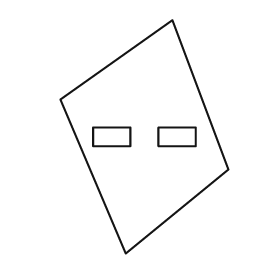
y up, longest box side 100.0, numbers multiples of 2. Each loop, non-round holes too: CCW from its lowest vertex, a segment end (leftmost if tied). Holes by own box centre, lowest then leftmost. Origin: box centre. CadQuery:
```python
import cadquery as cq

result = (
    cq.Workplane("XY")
    .moveTo(-8.0, -50.0)
    .lineTo(36.0, -14.0)
    .lineTo(12.0, 50.0)
    .lineTo(-36.0, 16.0)
    .close()
    .moveTo(-22.0, -4.0)
    .lineTo(-6.0, -4.0)
    .lineTo(-6.0, 4.0)
    .lineTo(-22.0, 4.0)
    .close()
    .moveTo(6.0, -4.0)
    .lineTo(22.0, -4.0)
    .lineTo(22.0, 4.0)
    .lineTo(6.0, 4.0)
    .close()
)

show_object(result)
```